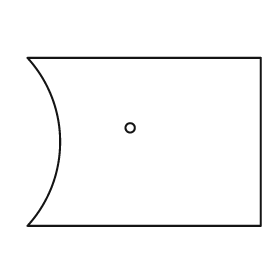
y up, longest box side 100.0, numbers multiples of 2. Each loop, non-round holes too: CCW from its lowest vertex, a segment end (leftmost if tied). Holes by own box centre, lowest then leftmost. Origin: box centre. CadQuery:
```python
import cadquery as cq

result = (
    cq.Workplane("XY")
    .moveTo(-50.0, -36.0)
    .lineTo(50.0, -36.0)
    .lineTo(50.0, 36.0)
    .lineTo(-50.0, 36.0)
    .threePointArc((-36.0, 0.0), (-50.0, -36.0))
    .close()
    .moveTo(-6.0, 6.0)
    .circle(2.0)
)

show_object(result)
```